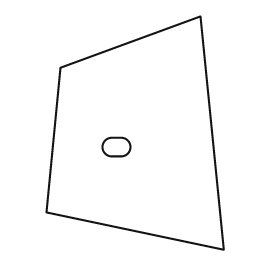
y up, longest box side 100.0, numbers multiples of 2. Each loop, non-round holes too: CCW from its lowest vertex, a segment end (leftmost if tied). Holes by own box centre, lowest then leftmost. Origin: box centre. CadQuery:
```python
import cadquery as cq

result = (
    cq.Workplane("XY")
    .moveTo(38.0, -50.0)
    .lineTo(28.0, 50.0)
    .lineTo(-32.0, 28.0)
    .lineTo(-38.0, -34.0)
    .close()
    .moveTo(-10.0, -10.0)
    .lineTo(-6.0, -10.0)
    .threePointArc((-2.0, -6.0), (-6.0, -2.0))
    .lineTo(-10.0, -2.0)
    .threePointArc((-14.0, -6.0), (-10.0, -10.0))
    .close()
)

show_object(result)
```